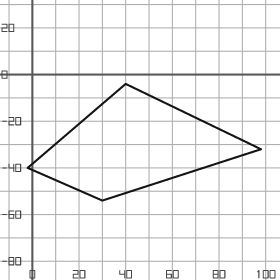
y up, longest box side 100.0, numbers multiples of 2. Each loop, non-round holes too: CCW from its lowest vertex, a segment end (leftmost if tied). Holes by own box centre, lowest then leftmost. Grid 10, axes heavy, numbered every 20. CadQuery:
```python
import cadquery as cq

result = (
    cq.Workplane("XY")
    .moveTo(30.0, -54.0)
    .lineTo(98.0, -32.0)
    .lineTo(40.0, -4.0)
    .lineTo(-2.0, -40.0)
    .close()
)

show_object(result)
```